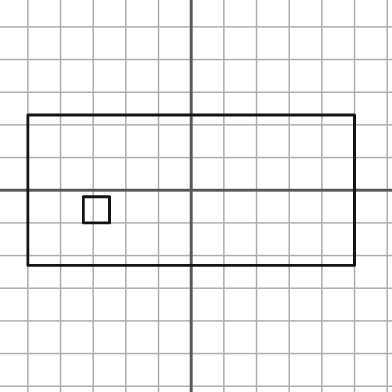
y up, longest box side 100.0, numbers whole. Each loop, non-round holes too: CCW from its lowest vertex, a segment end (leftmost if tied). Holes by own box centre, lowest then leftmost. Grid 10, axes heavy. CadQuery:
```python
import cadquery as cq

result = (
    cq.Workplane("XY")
    .moveTo(-50.0, -23.0)
    .lineTo(50.0, -23.0)
    .lineTo(50.0, 23.0)
    .lineTo(-50.0, 23.0)
    .close()
    .moveTo(-33.0, -10.0)
    .lineTo(-25.0, -10.0)
    .lineTo(-25.0, -2.0)
    .lineTo(-33.0, -2.0)
    .close()
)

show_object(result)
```